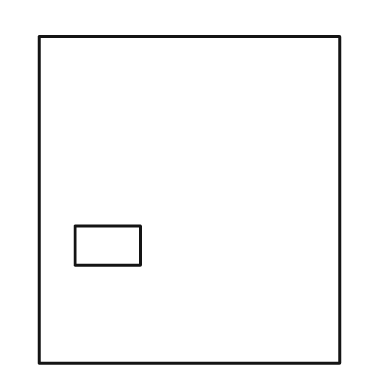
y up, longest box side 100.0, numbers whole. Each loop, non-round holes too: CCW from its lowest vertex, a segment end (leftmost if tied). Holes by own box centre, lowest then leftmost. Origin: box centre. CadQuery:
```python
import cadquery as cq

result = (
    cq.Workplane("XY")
    .moveTo(-46.0, -50.0)
    .lineTo(46.0, -50.0)
    .lineTo(46.0, 50.0)
    .lineTo(-46.0, 50.0)
    .close()
    .moveTo(-35.0, -20.0)
    .lineTo(-15.0, -20.0)
    .lineTo(-15.0, -8.0)
    .lineTo(-35.0, -8.0)
    .close()
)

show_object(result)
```